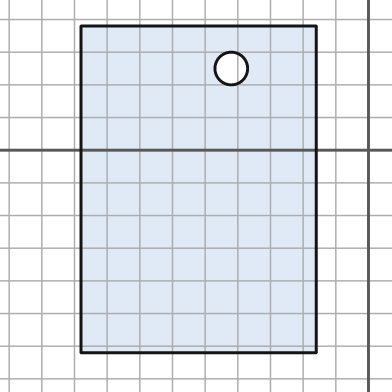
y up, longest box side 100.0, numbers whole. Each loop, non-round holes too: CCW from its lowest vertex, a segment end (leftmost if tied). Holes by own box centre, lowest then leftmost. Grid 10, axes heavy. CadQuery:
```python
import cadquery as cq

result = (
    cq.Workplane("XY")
    .moveTo(-88.0, -62.0)
    .lineTo(-16.0, -62.0)
    .lineTo(-16.0, 38.0)
    .lineTo(-88.0, 38.0)
    .close()
    .moveTo(-42.0, 25.0)
    .circle(5.0)
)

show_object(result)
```